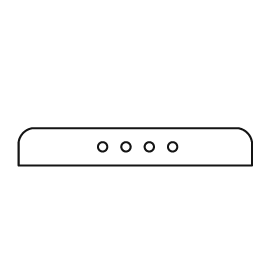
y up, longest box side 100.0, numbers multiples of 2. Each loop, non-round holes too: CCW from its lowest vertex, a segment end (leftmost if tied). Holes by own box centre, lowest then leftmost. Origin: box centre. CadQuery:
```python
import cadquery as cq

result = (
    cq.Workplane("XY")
    .moveTo(-50.0, -8.0)
    .lineTo(50.0, -8.0)
    .lineTo(50.0, 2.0)
    .threePointArc((48.0, 6.0), (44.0, 8.0))
    .lineTo(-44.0, 8.0)
    .threePointArc((-48.0, 6.0), (-50.0, 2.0))
    .close()
    .moveTo(-14.0, 0.0)
    .circle(2.0)
    .moveTo(-4.0, 0.0)
    .circle(2.0)
    .moveTo(6.0, 0.0)
    .circle(2.0)
    .moveTo(16.0, 0.0)
    .circle(2.0)
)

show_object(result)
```